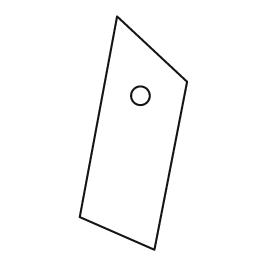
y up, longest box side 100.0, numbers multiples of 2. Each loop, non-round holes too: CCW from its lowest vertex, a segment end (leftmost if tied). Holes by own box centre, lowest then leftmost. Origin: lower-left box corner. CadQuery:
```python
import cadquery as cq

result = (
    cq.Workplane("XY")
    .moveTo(32.0, 0.0)
    .lineTo(46.0, 72.0)
    .lineTo(16.0, 100.0)
    .lineTo(0.0, 14.0)
    .close()
    .moveTo(26.0, 66.0)
    .circle(4.0)
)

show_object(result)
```